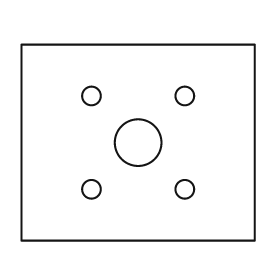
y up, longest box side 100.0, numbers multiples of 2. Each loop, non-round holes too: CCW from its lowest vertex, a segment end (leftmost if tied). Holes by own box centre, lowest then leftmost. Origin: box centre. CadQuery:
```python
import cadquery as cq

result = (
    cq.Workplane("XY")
    .moveTo(-50.0, -42.0)
    .lineTo(50.0, -42.0)
    .lineTo(50.0, 42.0)
    .lineTo(-50.0, 42.0)
    .close()
    .moveTo(-20.0, -20.0)
    .circle(4.0)
    .moveTo(20.0, -20.0)
    .circle(4.0)
    .moveTo(0.0, 0.0)
    .circle(10.0)
    .moveTo(-20.0, 20.0)
    .circle(4.0)
    .moveTo(20.0, 20.0)
    .circle(4.0)
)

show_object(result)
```